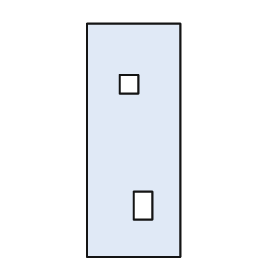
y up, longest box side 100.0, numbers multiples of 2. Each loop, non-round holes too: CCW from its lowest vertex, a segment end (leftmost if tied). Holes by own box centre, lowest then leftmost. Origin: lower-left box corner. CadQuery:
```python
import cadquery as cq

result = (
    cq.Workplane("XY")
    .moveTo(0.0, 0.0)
    .lineTo(40.0, 0.0)
    .lineTo(40.0, 100.0)
    .lineTo(0.0, 100.0)
    .close()
    .moveTo(20.0, 16.0)
    .lineTo(28.0, 16.0)
    .lineTo(28.0, 28.0)
    .lineTo(20.0, 28.0)
    .close()
    .moveTo(14.0, 70.0)
    .lineTo(22.0, 70.0)
    .lineTo(22.0, 78.0)
    .lineTo(14.0, 78.0)
    .close()
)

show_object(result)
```